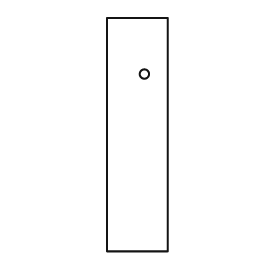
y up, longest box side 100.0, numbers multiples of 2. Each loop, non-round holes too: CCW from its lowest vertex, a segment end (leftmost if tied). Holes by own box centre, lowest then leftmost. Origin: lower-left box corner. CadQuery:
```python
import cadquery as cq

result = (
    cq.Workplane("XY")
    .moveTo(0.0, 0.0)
    .lineTo(26.0, 0.0)
    .lineTo(26.0, 100.0)
    .lineTo(0.0, 100.0)
    .close()
    .moveTo(16.0, 76.0)
    .circle(2.0)
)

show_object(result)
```